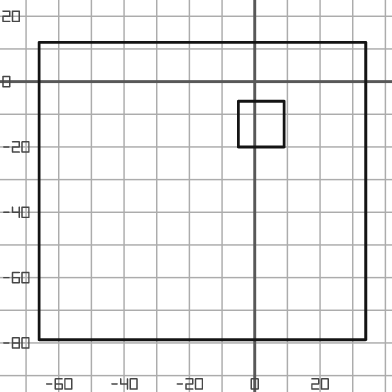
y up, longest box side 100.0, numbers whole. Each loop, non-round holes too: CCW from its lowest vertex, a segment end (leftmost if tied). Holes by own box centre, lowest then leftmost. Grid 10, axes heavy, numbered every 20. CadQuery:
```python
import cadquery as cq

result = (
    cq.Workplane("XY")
    .moveTo(-66.0, -79.0)
    .lineTo(34.0, -79.0)
    .lineTo(34.0, 12.0)
    .lineTo(-66.0, 12.0)
    .close()
    .moveTo(-5.0, -20.0)
    .lineTo(9.0, -20.0)
    .lineTo(9.0, -6.0)
    .lineTo(-5.0, -6.0)
    .close()
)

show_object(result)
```